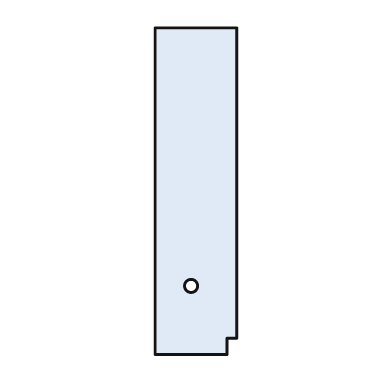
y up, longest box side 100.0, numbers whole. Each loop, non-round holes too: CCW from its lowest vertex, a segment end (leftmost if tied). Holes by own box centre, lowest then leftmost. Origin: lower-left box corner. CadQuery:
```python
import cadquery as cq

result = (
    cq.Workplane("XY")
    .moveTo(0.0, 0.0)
    .lineTo(22.0, 0.0)
    .lineTo(22.0, 5.0)
    .lineTo(25.0, 5.0)
    .lineTo(25.0, 100.0)
    .lineTo(0.0, 100.0)
    .close()
    .moveTo(11.0, 21.0)
    .circle(2.0)
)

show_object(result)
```